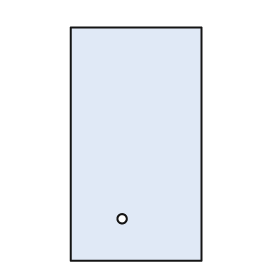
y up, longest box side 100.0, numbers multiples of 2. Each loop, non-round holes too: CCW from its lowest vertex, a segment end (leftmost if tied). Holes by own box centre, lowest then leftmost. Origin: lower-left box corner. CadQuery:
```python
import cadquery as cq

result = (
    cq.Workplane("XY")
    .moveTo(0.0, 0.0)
    .lineTo(56.0, 0.0)
    .lineTo(56.0, 100.0)
    .lineTo(0.0, 100.0)
    .close()
    .moveTo(22.0, 18.0)
    .circle(2.0)
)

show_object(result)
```